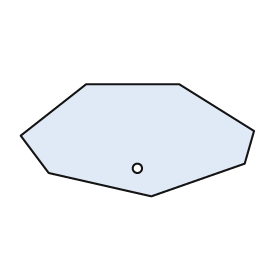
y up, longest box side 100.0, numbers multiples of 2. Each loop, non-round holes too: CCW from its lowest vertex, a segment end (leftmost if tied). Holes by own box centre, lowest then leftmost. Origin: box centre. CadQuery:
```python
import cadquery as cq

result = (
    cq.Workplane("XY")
    .moveTo(6.0, -24.0)
    .lineTo(46.0, -10.0)
    .lineTo(50.0, 4.0)
    .lineTo(18.0, 24.0)
    .lineTo(-22.0, 24.0)
    .lineTo(-50.0, 2.0)
    .lineTo(-38.0, -14.0)
    .close()
    .moveTo(0.0, -12.0)
    .circle(2.0)
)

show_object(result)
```